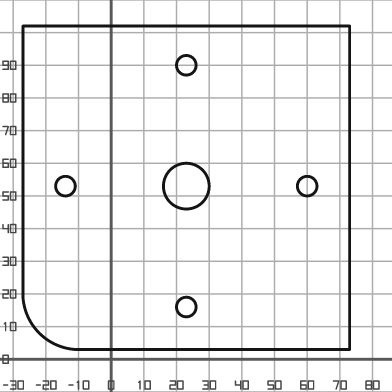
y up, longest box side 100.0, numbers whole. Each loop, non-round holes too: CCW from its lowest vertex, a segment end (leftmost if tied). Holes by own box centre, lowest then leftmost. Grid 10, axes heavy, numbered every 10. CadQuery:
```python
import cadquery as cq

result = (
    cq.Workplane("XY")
    .moveTo(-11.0, 3.0)
    .lineTo(73.0, 3.0)
    .lineTo(73.0, 102.0)
    .lineTo(-27.0, 102.0)
    .lineTo(-27.0, 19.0)
    .threePointArc((-22.0, 8.0), (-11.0, 3.0))
    .close()
    .moveTo(23.0, 16.0)
    .circle(3.0)
    .moveTo(-14.0, 53.0)
    .circle(3.0)
    .moveTo(23.0, 53.0)
    .circle(7.0)
    .moveTo(60.0, 53.0)
    .circle(3.0)
    .moveTo(23.0, 90.0)
    .circle(3.0)
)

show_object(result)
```